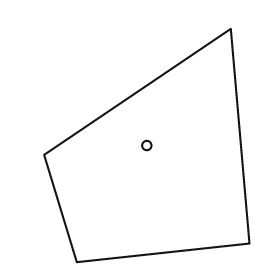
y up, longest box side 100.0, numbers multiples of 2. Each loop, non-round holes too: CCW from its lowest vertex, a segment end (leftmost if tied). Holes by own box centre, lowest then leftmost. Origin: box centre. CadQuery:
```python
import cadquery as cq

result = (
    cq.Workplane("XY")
    .moveTo(-30.0, -50.0)
    .lineTo(44.0, -42.0)
    .lineTo(36.0, 50.0)
    .lineTo(-44.0, -4.0)
    .close()
    .moveTo(0.0, 0.0)
    .circle(2.0)
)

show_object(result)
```